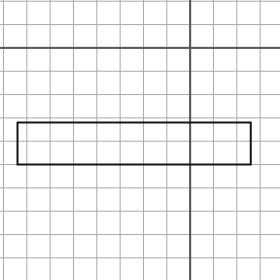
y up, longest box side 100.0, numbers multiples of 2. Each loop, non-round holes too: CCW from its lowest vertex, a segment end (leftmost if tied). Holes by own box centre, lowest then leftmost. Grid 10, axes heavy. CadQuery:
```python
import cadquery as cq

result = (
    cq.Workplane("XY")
    .moveTo(-74.0, -50.0)
    .lineTo(26.0, -50.0)
    .lineTo(26.0, -32.0)
    .lineTo(-74.0, -32.0)
    .close()
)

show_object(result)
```